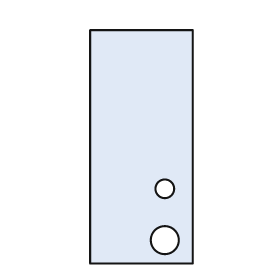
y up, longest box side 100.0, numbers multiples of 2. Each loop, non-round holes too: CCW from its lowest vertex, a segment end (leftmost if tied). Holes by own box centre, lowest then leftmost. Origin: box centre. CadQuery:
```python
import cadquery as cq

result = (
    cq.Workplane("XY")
    .moveTo(-22.0, -50.0)
    .lineTo(22.0, -50.0)
    .lineTo(22.0, 50.0)
    .lineTo(-22.0, 50.0)
    .close()
    .moveTo(10.0, -40.0)
    .circle(6.0)
    .moveTo(10.0, -18.0)
    .circle(4.0)
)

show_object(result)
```